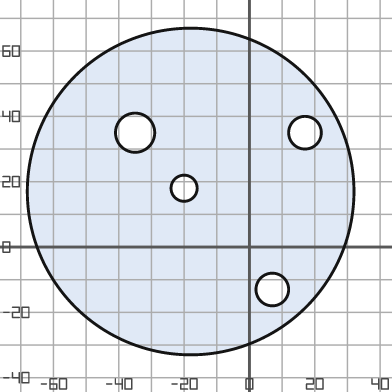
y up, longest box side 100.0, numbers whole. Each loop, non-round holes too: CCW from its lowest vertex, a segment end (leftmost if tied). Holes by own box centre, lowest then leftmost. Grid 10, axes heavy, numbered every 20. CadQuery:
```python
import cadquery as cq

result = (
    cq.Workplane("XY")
    .moveTo(-18.0, 17.0)
    .circle(50.0)
    .moveTo(7.0, -13.0)
    .circle(5.0)
    .moveTo(-20.0, 18.0)
    .circle(4.0)
    .moveTo(-35.0, 35.0)
    .circle(6.0)
    .moveTo(17.0, 35.0)
    .circle(5.0)
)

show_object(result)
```